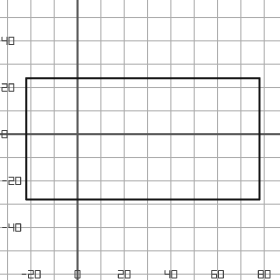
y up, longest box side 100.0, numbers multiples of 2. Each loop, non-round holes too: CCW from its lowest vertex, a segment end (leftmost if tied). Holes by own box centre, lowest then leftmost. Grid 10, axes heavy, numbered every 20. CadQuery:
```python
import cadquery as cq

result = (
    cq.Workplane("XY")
    .moveTo(-22.0, -28.0)
    .lineTo(78.0, -28.0)
    .lineTo(78.0, 24.0)
    .lineTo(-22.0, 24.0)
    .close()
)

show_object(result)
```